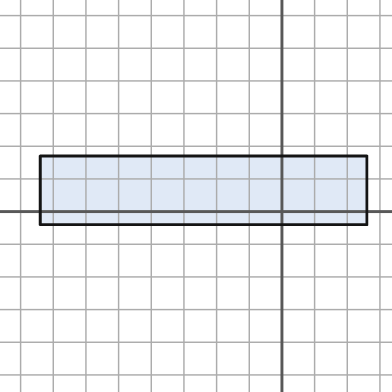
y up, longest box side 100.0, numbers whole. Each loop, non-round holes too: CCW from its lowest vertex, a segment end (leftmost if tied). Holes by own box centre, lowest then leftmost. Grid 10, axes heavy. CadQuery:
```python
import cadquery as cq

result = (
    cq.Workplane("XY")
    .moveTo(-74.0, -4.0)
    .lineTo(26.0, -4.0)
    .lineTo(26.0, 17.0)
    .lineTo(-74.0, 17.0)
    .close()
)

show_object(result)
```